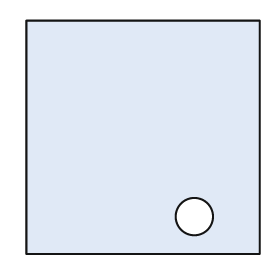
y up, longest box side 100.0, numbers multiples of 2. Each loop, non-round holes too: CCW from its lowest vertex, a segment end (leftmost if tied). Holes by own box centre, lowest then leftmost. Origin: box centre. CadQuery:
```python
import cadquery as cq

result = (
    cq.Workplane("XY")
    .moveTo(-50.0, -50.0)
    .lineTo(50.0, -50.0)
    .lineTo(50.0, 50.0)
    .lineTo(-50.0, 50.0)
    .close()
    .moveTo(22.0, -34.0)
    .circle(8.0)
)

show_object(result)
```